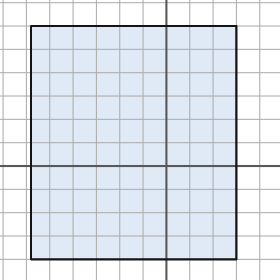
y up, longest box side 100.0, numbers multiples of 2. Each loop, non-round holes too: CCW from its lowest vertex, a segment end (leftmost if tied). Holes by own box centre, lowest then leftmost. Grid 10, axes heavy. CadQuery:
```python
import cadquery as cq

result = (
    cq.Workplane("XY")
    .moveTo(-58.0, -40.0)
    .lineTo(30.0, -40.0)
    .lineTo(30.0, 60.0)
    .lineTo(-58.0, 60.0)
    .close()
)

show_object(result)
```